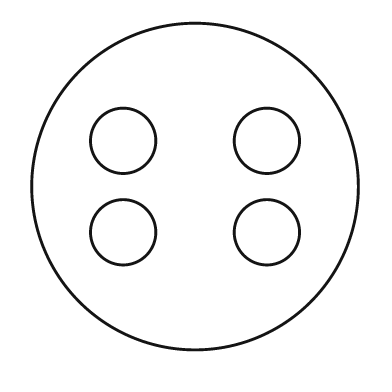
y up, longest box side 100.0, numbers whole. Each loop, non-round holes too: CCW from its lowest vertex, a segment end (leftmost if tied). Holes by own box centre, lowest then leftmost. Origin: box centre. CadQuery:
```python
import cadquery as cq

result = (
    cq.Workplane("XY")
    .moveTo(0.0, 0.0)
    .circle(50.0)
    .moveTo(-22.0, -14.0)
    .circle(10.0)
    .moveTo(22.0, -14.0)
    .circle(10.0)
    .moveTo(-22.0, 14.0)
    .circle(10.0)
    .moveTo(22.0, 14.0)
    .circle(10.0)
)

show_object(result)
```